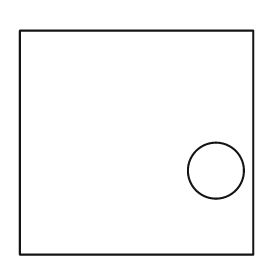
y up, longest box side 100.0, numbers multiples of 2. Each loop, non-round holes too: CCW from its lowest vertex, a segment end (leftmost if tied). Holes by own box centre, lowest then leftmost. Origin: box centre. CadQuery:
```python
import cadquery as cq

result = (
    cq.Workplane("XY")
    .moveTo(-50.0, -48.0)
    .lineTo(50.0, -48.0)
    .lineTo(50.0, 48.0)
    .lineTo(-50.0, 48.0)
    .close()
    .moveTo(34.0, -12.0)
    .circle(12.0)
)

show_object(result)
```